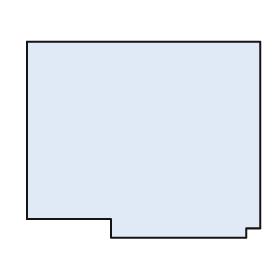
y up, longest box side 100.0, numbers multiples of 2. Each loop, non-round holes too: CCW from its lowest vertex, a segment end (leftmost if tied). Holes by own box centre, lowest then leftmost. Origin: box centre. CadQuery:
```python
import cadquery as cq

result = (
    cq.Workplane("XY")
    .moveTo(-14.0, -42.0)
    .lineTo(44.0, -42.0)
    .lineTo(44.0, -38.0)
    .lineTo(50.0, -38.0)
    .lineTo(50.0, 42.0)
    .lineTo(-50.0, 42.0)
    .lineTo(-50.0, -34.0)
    .lineTo(-14.0, -34.0)
    .close()
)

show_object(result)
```